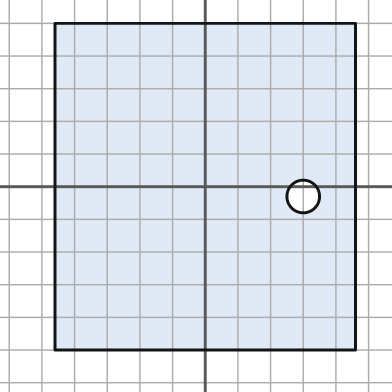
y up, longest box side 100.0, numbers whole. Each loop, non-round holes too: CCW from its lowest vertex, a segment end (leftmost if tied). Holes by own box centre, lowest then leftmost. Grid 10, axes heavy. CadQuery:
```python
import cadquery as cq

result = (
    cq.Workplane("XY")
    .moveTo(-46.0, -50.0)
    .lineTo(46.0, -50.0)
    .lineTo(46.0, 50.0)
    .lineTo(-46.0, 50.0)
    .close()
    .moveTo(30.0, -3.0)
    .circle(5.0)
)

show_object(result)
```